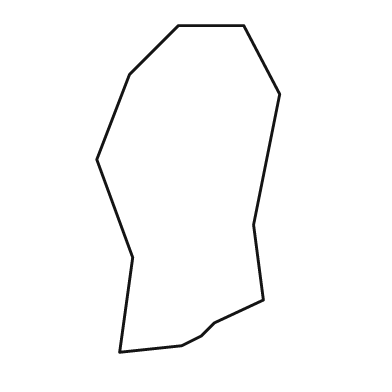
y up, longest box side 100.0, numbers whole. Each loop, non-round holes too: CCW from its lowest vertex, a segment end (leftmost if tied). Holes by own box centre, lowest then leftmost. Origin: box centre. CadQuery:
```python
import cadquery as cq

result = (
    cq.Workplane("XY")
    .moveTo(-21.0, -50.0)
    .lineTo(-2.0, -48.0)
    .lineTo(4.0, -45.0)
    .lineTo(8.0, -41.0)
    .lineTo(23.0, -34.0)
    .lineTo(20.0, -11.0)
    .lineTo(28.0, 29.0)
    .lineTo(17.0, 50.0)
    .lineTo(-3.0, 50.0)
    .lineTo(-18.0, 35.0)
    .lineTo(-28.0, 9.0)
    .lineTo(-17.0, -21.0)
    .close()
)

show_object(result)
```